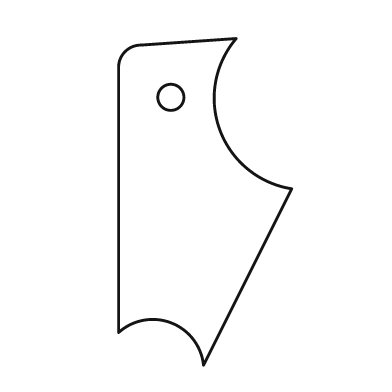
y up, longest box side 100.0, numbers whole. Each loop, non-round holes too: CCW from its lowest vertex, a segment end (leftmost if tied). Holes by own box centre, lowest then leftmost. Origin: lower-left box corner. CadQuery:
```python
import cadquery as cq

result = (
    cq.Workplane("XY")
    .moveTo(26.0, 0.0)
    .lineTo(53.0, 54.0)
    .threePointArc((31.0, 72.0), (36.0, 100.0))
    .lineTo(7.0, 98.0)
    .threePointArc((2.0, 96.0), (0.0, 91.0))
    .lineTo(0.0, 10.0)
    .threePointArc((16.0, 13.0), (26.0, 0.0))
    .close()
    .moveTo(16.0, 82.0)
    .circle(4.0)
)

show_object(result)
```